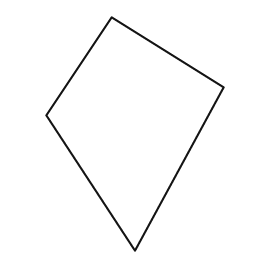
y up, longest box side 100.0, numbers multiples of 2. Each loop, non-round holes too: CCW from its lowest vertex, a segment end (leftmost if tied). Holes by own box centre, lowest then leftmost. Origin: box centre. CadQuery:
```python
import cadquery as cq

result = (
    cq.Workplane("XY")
    .moveTo(0.0, -50.0)
    .lineTo(38.0, 20.0)
    .lineTo(-10.0, 50.0)
    .lineTo(-38.0, 8.0)
    .close()
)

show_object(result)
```